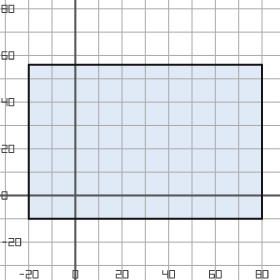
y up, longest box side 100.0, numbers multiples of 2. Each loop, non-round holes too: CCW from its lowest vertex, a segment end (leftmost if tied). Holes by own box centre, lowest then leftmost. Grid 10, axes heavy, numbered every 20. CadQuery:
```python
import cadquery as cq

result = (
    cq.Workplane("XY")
    .moveTo(-20.0, -10.0)
    .lineTo(80.0, -10.0)
    .lineTo(80.0, 56.0)
    .lineTo(-20.0, 56.0)
    .close()
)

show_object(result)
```